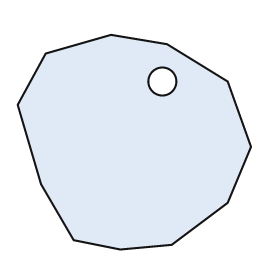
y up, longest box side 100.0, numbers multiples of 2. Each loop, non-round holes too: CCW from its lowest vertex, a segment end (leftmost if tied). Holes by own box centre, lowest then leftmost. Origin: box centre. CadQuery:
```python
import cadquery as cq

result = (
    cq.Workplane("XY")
    .moveTo(-6.0, -46.0)
    .lineTo(16.0, -44.0)
    .lineTo(40.0, -26.0)
    .lineTo(50.0, -2.0)
    .lineTo(40.0, 26.0)
    .lineTo(14.0, 42.0)
    .lineTo(-10.0, 46.0)
    .lineTo(-38.0, 38.0)
    .lineTo(-50.0, 16.0)
    .lineTo(-40.0, -18.0)
    .lineTo(-26.0, -42.0)
    .close()
    .moveTo(12.0, 26.0)
    .circle(6.0)
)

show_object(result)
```